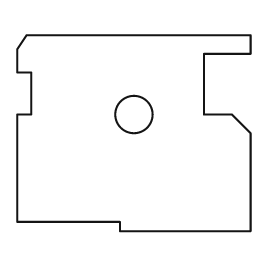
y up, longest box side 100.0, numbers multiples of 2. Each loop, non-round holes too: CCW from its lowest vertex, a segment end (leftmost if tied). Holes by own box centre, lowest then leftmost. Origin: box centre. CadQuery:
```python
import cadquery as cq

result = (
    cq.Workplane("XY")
    .moveTo(-6.0, -42.0)
    .lineTo(50.0, -42.0)
    .lineTo(50.0, 0.0)
    .lineTo(42.0, 8.0)
    .lineTo(30.0, 8.0)
    .lineTo(30.0, 34.0)
    .lineTo(50.0, 34.0)
    .lineTo(50.0, 42.0)
    .lineTo(-46.0, 42.0)
    .lineTo(-50.0, 36.0)
    .lineTo(-50.0, 26.0)
    .lineTo(-44.0, 26.0)
    .lineTo(-44.0, 8.0)
    .lineTo(-50.0, 8.0)
    .lineTo(-50.0, -38.0)
    .lineTo(-6.0, -38.0)
    .close()
    .moveTo(0.0, 8.0)
    .circle(8.0)
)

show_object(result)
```